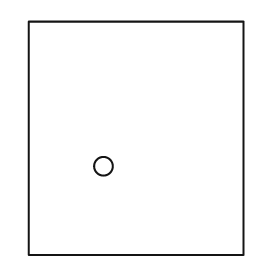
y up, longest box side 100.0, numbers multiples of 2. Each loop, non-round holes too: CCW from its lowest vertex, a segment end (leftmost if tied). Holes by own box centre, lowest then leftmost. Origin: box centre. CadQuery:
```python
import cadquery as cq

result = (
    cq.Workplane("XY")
    .moveTo(-46.0, -50.0)
    .lineTo(46.0, -50.0)
    .lineTo(46.0, 50.0)
    .lineTo(-46.0, 50.0)
    .close()
    .moveTo(-14.0, -12.0)
    .circle(4.0)
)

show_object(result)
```